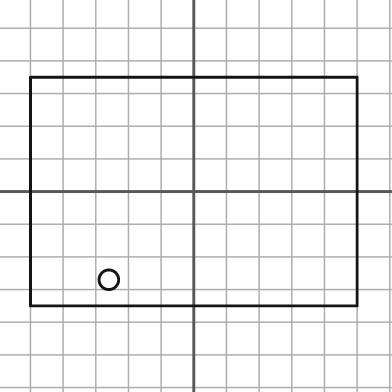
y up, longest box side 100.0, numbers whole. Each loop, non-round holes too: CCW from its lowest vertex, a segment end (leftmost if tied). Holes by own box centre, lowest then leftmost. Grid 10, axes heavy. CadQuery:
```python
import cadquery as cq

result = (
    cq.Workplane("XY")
    .moveTo(-50.0, -35.0)
    .lineTo(50.0, -35.0)
    .lineTo(50.0, 35.0)
    .lineTo(-50.0, 35.0)
    .close()
    .moveTo(-26.0, -27.0)
    .circle(3.0)
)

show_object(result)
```